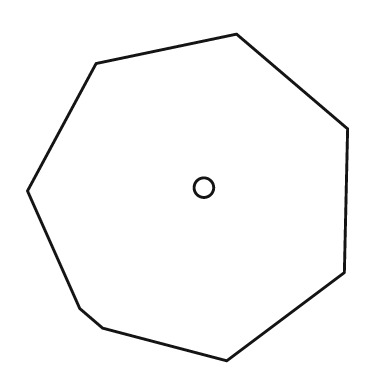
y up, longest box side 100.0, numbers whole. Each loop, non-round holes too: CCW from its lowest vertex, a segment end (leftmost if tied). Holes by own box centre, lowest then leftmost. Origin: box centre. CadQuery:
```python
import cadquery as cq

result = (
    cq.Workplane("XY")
    .moveTo(12.0, -50.0)
    .lineTo(48.0, -23.0)
    .lineTo(49.0, 21.0)
    .lineTo(15.0, 50.0)
    .lineTo(-28.0, 41.0)
    .lineTo(-49.0, 2.0)
    .lineTo(-33.0, -34.0)
    .lineTo(-26.0, -40.0)
    .close()
    .moveTo(5.0, 3.0)
    .circle(3.0)
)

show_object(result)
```